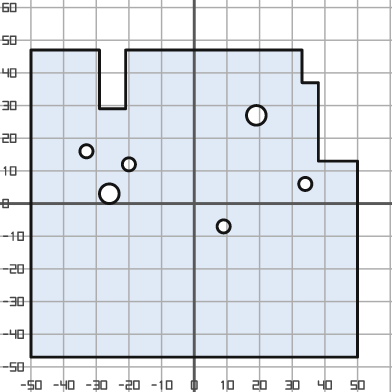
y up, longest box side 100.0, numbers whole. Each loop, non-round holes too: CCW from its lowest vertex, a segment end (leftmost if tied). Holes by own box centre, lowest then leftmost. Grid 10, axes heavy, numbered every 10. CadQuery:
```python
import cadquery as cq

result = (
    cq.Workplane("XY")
    .moveTo(-50.0, -47.0)
    .lineTo(50.0, -47.0)
    .lineTo(50.0, 13.0)
    .lineTo(38.0, 13.0)
    .lineTo(38.0, 37.0)
    .lineTo(33.0, 37.0)
    .lineTo(33.0, 47.0)
    .lineTo(-21.0, 47.0)
    .lineTo(-21.0, 29.0)
    .lineTo(-29.0, 29.0)
    .lineTo(-29.0, 47.0)
    .lineTo(-50.0, 47.0)
    .close()
    .moveTo(9.0, -7.0)
    .circle(2.0)
    .moveTo(-26.0, 3.0)
    .circle(3.0)
    .moveTo(34.0, 6.0)
    .circle(2.0)
    .moveTo(-20.0, 12.0)
    .circle(2.0)
    .moveTo(-33.0, 16.0)
    .circle(2.0)
    .moveTo(19.0, 27.0)
    .circle(3.0)
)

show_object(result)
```